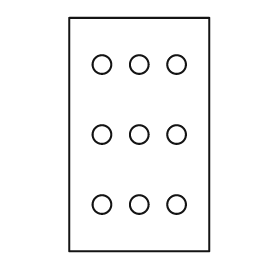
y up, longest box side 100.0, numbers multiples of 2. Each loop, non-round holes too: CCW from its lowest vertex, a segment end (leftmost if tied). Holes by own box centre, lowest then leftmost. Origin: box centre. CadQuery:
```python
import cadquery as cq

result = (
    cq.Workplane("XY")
    .moveTo(-30.0, -50.0)
    .lineTo(30.0, -50.0)
    .lineTo(30.0, 50.0)
    .lineTo(-30.0, 50.0)
    .close()
    .moveTo(-16.0, -30.0)
    .circle(4.0)
    .moveTo(0.0, -30.0)
    .circle(4.0)
    .moveTo(16.0, -30.0)
    .circle(4.0)
    .moveTo(-16.0, 0.0)
    .circle(4.0)
    .moveTo(0.0, 0.0)
    .circle(4.0)
    .moveTo(16.0, 0.0)
    .circle(4.0)
    .moveTo(-16.0, 30.0)
    .circle(4.0)
    .moveTo(0.0, 30.0)
    .circle(4.0)
    .moveTo(16.0, 30.0)
    .circle(4.0)
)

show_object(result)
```